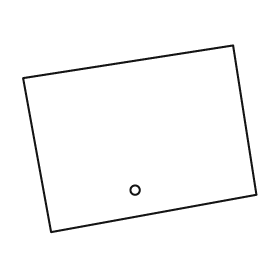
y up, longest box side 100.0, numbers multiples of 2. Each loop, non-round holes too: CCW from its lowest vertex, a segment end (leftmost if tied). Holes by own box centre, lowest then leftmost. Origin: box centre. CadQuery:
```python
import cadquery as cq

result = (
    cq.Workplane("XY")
    .moveTo(-38.0, -40.0)
    .lineTo(50.0, -24.0)
    .lineTo(40.0, 40.0)
    .lineTo(-50.0, 26.0)
    .close()
    .moveTo(-2.0, -22.0)
    .circle(2.0)
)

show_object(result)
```